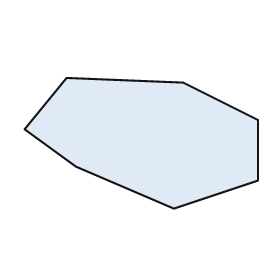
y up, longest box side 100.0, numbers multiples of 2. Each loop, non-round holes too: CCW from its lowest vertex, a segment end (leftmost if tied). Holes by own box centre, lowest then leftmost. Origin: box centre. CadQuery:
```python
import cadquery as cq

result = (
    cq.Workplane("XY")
    .moveTo(14.0, -28.0)
    .lineTo(50.0, -16.0)
    .lineTo(50.0, 10.0)
    .lineTo(18.0, 26.0)
    .lineTo(-32.0, 28.0)
    .lineTo(-50.0, 6.0)
    .lineTo(-28.0, -10.0)
    .close()
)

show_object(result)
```